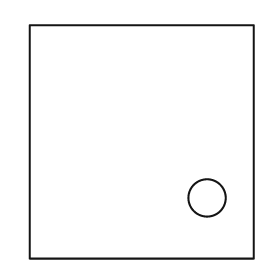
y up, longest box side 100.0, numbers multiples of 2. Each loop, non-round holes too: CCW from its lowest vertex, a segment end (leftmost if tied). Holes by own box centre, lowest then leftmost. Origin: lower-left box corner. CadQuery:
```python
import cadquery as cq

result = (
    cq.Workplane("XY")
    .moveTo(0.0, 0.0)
    .lineTo(96.0, 0.0)
    .lineTo(96.0, 100.0)
    .lineTo(0.0, 100.0)
    .close()
    .moveTo(76.0, 26.0)
    .circle(8.0)
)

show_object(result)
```